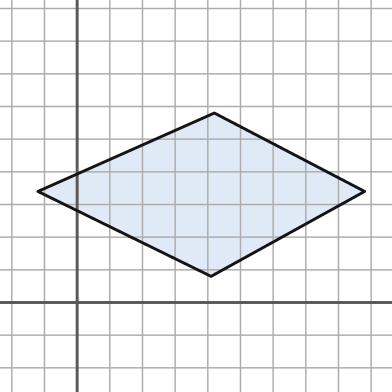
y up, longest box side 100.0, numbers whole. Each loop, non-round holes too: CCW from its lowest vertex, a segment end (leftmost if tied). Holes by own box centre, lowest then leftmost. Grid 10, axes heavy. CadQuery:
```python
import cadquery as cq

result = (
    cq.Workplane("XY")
    .moveTo(41.0, 8.0)
    .lineTo(88.0, 34.0)
    .lineTo(42.0, 58.0)
    .lineTo(-12.0, 34.0)
    .close()
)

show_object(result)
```